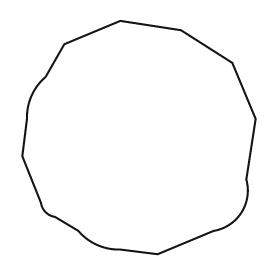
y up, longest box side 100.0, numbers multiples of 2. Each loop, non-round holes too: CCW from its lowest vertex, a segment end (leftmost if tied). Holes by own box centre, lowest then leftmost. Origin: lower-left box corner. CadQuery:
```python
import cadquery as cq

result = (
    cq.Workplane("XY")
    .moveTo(58.0, 0.0)
    .lineTo(82.0, 10.0)
    .threePointArc((94.0, 18.0), (96.0, 32.0))
    .lineTo(100.0, 58.0)
    .lineTo(90.0, 82.0)
    .lineTo(68.0, 96.0)
    .lineTo(42.0, 100.0)
    .lineTo(18.0, 90.0)
    .lineTo(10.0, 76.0)
    .threePointArc((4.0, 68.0), (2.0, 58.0))
    .lineTo(0.0, 42.0)
    .lineTo(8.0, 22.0)
    .threePointArc((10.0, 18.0), (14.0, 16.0))
    .lineTo(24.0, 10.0)
    .threePointArc((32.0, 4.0), (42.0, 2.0))
    .close()
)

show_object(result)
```